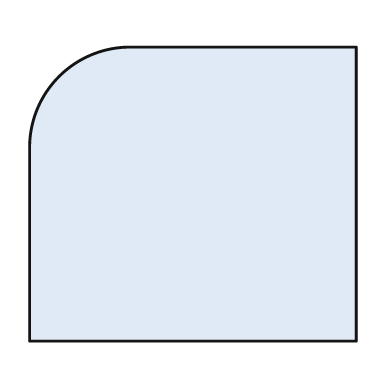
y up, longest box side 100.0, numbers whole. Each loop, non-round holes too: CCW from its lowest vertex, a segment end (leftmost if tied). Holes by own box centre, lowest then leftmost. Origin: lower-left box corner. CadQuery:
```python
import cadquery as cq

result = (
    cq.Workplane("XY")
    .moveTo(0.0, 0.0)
    .lineTo(100.0, 0.0)
    .lineTo(100.0, 90.0)
    .lineTo(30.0, 90.0)
    .threePointArc((9.0, 81.0), (0.0, 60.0))
    .close()
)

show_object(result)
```